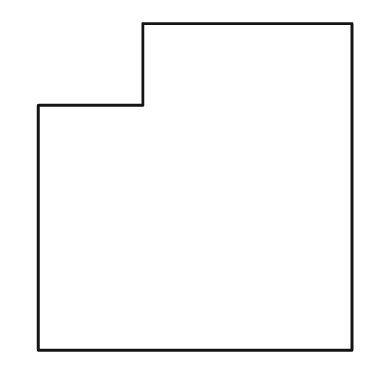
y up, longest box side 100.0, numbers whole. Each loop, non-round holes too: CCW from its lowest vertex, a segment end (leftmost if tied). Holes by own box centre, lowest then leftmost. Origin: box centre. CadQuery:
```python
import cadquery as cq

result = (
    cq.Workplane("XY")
    .moveTo(-48.0, -50.0)
    .lineTo(48.0, -50.0)
    .lineTo(48.0, 50.0)
    .lineTo(-16.0, 50.0)
    .lineTo(-16.0, 25.0)
    .lineTo(-48.0, 25.0)
    .close()
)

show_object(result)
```